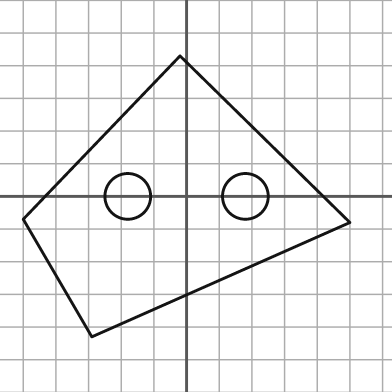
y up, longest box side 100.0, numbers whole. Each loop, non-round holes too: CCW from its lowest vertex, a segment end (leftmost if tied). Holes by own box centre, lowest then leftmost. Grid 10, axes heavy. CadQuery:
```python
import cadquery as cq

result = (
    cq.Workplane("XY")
    .moveTo(-29.0, -43.0)
    .lineTo(50.0, -8.0)
    .lineTo(-2.0, 43.0)
    .lineTo(-50.0, -7.0)
    .close()
    .moveTo(-18.0, 0.0)
    .circle(7.0)
    .moveTo(18.0, 0.0)
    .circle(7.0)
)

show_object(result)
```